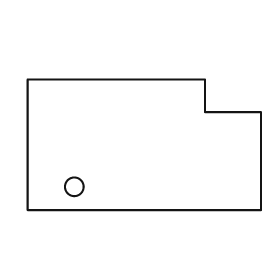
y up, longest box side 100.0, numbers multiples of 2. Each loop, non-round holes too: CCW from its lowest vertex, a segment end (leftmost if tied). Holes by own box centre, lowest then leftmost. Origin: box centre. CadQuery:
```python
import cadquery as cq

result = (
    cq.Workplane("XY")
    .moveTo(-50.0, -28.0)
    .lineTo(50.0, -28.0)
    .lineTo(50.0, 14.0)
    .lineTo(26.0, 14.0)
    .lineTo(26.0, 28.0)
    .lineTo(-50.0, 28.0)
    .close()
    .moveTo(-30.0, -18.0)
    .circle(4.0)
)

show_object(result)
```